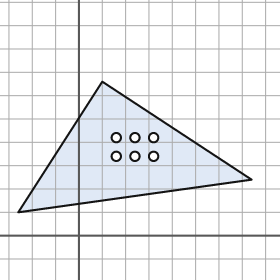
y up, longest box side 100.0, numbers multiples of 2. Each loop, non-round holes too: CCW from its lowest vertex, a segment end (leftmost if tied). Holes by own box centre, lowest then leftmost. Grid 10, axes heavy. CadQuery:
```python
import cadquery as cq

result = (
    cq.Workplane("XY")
    .moveTo(-26.0, 10.0)
    .lineTo(74.0, 24.0)
    .lineTo(10.0, 66.0)
    .close()
    .moveTo(16.0, 34.0)
    .circle(2.0)
    .moveTo(24.0, 34.0)
    .circle(2.0)
    .moveTo(32.0, 34.0)
    .circle(2.0)
    .moveTo(16.0, 42.0)
    .circle(2.0)
    .moveTo(24.0, 42.0)
    .circle(2.0)
    .moveTo(32.0, 42.0)
    .circle(2.0)
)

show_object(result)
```